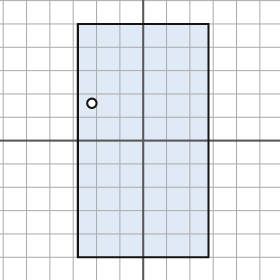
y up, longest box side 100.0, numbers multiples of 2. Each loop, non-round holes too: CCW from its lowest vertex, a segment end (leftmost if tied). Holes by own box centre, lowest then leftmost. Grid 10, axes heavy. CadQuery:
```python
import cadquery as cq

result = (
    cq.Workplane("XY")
    .moveTo(-28.0, -50.0)
    .lineTo(28.0, -50.0)
    .lineTo(28.0, 50.0)
    .lineTo(-28.0, 50.0)
    .close()
    .moveTo(-22.0, 16.0)
    .circle(2.0)
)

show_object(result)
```